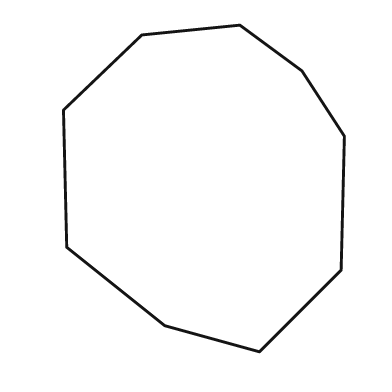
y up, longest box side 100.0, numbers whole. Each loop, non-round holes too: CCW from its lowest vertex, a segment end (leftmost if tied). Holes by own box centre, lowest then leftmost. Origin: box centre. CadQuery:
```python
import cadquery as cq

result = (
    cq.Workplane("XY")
    .moveTo(17.0, -50.0)
    .lineTo(42.0, -25.0)
    .lineTo(43.0, 16.0)
    .lineTo(30.0, 36.0)
    .lineTo(11.0, 50.0)
    .lineTo(-19.0, 47.0)
    .lineTo(-43.0, 24.0)
    .lineTo(-42.0, -18.0)
    .lineTo(-12.0, -42.0)
    .close()
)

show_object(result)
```